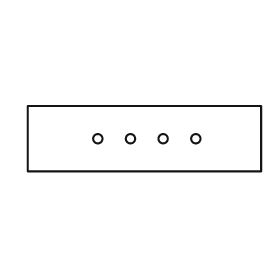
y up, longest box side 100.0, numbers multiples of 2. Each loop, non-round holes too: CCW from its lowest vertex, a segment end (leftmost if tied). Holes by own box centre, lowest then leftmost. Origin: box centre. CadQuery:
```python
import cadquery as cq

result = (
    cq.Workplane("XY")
    .moveTo(-50.0, -14.0)
    .lineTo(50.0, -14.0)
    .lineTo(50.0, 14.0)
    .lineTo(-50.0, 14.0)
    .close()
    .moveTo(-20.0, 0.0)
    .circle(2.0)
    .moveTo(-6.0, 0.0)
    .circle(2.0)
    .moveTo(8.0, 0.0)
    .circle(2.0)
    .moveTo(22.0, 0.0)
    .circle(2.0)
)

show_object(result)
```